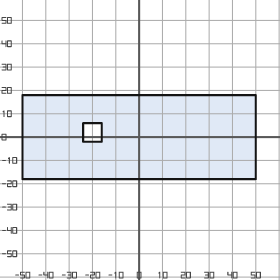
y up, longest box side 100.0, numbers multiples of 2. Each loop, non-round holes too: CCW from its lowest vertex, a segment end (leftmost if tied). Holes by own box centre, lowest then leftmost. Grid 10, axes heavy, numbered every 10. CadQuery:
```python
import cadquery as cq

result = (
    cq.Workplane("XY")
    .moveTo(-50.0, -18.0)
    .lineTo(50.0, -18.0)
    .lineTo(50.0, 18.0)
    .lineTo(-50.0, 18.0)
    .close()
    .moveTo(-24.0, -2.0)
    .lineTo(-16.0, -2.0)
    .lineTo(-16.0, 6.0)
    .lineTo(-24.0, 6.0)
    .close()
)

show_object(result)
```